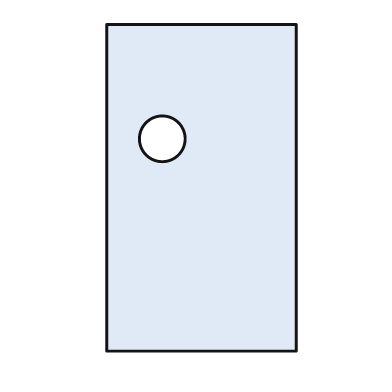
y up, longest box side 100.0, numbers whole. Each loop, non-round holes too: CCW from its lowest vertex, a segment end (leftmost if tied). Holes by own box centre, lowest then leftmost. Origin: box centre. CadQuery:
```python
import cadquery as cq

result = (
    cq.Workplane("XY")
    .moveTo(-29.0, -50.0)
    .lineTo(29.0, -50.0)
    .lineTo(29.0, 50.0)
    .lineTo(-29.0, 50.0)
    .close()
    .moveTo(-12.0, 15.0)
    .circle(7.0)
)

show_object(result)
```